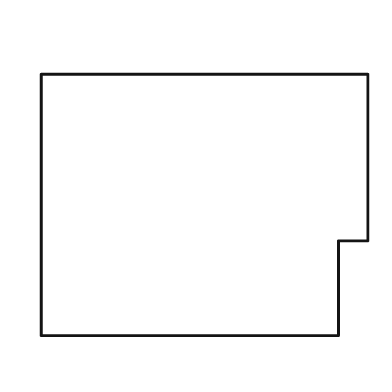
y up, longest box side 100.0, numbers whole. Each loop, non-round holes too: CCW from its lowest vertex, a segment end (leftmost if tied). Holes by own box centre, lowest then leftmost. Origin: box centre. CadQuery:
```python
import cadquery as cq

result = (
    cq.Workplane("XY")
    .moveTo(-50.0, -40.0)
    .lineTo(41.0, -40.0)
    .lineTo(41.0, -11.0)
    .lineTo(50.0, -11.0)
    .lineTo(50.0, 40.0)
    .lineTo(-50.0, 40.0)
    .close()
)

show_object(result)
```